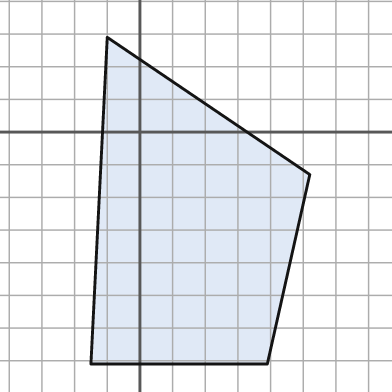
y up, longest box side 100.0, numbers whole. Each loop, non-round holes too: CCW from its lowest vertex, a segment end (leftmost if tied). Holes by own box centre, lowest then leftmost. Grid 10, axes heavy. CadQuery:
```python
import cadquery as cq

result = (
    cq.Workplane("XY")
    .moveTo(-15.0, -71.0)
    .lineTo(39.0, -71.0)
    .lineTo(52.0, -13.0)
    .lineTo(-10.0, 29.0)
    .close()
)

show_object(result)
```